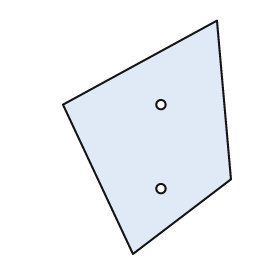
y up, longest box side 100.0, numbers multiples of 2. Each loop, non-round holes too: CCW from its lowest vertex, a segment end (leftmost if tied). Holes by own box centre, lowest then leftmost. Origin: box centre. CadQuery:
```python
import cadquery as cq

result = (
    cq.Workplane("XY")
    .moveTo(-6.0, -50.0)
    .lineTo(36.0, -18.0)
    .lineTo(30.0, 50.0)
    .lineTo(-36.0, 14.0)
    .close()
    .moveTo(6.0, -22.0)
    .circle(2.0)
    .moveTo(6.0, 14.0)
    .circle(2.0)
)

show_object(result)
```